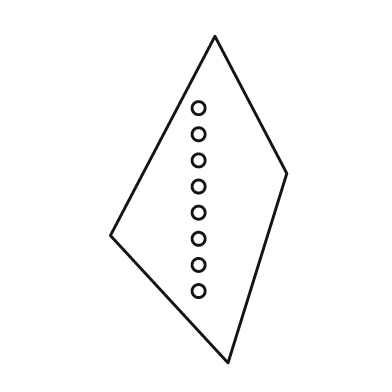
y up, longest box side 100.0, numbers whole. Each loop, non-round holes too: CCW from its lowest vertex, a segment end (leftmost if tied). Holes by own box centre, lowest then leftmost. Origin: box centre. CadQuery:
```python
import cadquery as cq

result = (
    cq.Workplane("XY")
    .moveTo(9.0, -50.0)
    .lineTo(27.0, 8.0)
    .lineTo(5.0, 50.0)
    .lineTo(-27.0, -11.0)
    .close()
    .moveTo(0.0, -28.0)
    .circle(2.0)
    .moveTo(0.0, -20.0)
    .circle(2.0)
    .moveTo(0.0, -12.0)
    .circle(2.0)
    .moveTo(0.0, -4.0)
    .circle(2.0)
    .moveTo(0.0, 4.0)
    .circle(2.0)
    .moveTo(0.0, 12.0)
    .circle(2.0)
    .moveTo(0.0, 20.0)
    .circle(2.0)
    .moveTo(0.0, 28.0)
    .circle(2.0)
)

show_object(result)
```